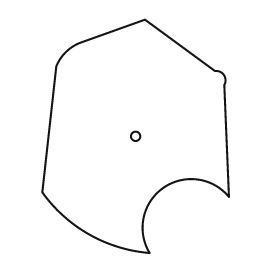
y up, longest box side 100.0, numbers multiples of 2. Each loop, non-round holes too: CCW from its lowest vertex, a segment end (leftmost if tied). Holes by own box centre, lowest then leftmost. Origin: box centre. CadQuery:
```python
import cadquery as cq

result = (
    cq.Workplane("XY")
    .moveTo(6.0, -50.0)
    .threePointArc((12.0, -22.0), (40.0, -26.0))
    .lineTo(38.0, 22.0)
    .threePointArc((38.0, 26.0), (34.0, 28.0))
    .lineTo(4.0, 50.0)
    .lineTo(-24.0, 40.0)
    .threePointArc((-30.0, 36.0), (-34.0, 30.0))
    .lineTo(-40.0, -24.0)
    .threePointArc((-20.0, -42.0), (6.0, -50.0))
    .close()
    .moveTo(0.0, 0.0)
    .circle(2.0)
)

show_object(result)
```